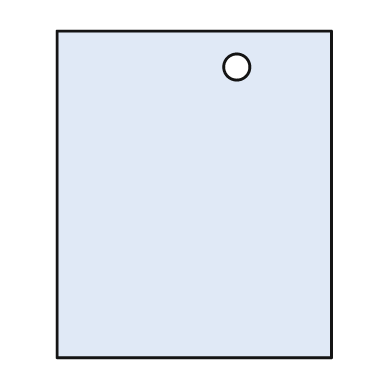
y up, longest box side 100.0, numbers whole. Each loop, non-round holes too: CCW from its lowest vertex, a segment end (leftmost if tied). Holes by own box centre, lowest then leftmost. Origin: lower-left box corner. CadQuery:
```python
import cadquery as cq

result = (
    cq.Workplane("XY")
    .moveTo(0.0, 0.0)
    .lineTo(84.0, 0.0)
    .lineTo(84.0, 100.0)
    .lineTo(0.0, 100.0)
    .close()
    .moveTo(55.0, 89.0)
    .circle(4.0)
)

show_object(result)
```